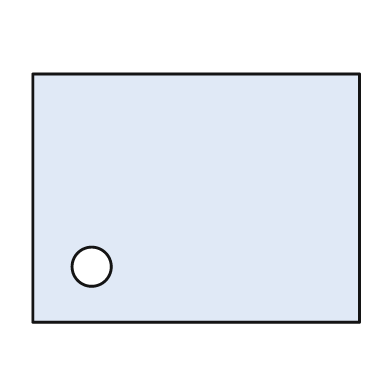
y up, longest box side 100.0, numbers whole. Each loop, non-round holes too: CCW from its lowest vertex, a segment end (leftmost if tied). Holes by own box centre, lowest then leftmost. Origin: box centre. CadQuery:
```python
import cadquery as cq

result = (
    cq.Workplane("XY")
    .moveTo(-50.0, -38.0)
    .lineTo(50.0, -38.0)
    .lineTo(50.0, 38.0)
    .lineTo(-50.0, 38.0)
    .close()
    .moveTo(-32.0, -21.0)
    .circle(6.0)
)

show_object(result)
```